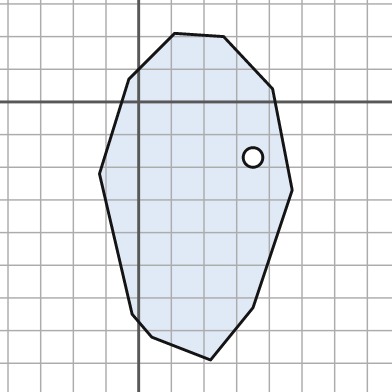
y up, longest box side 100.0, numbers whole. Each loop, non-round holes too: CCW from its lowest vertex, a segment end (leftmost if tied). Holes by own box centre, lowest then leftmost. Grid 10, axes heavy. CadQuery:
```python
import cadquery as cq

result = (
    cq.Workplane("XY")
    .moveTo(22.0, -79.0)
    .lineTo(35.0, -63.0)
    .lineTo(47.0, -27.0)
    .lineTo(41.0, 4.0)
    .lineTo(26.0, 20.0)
    .lineTo(11.0, 21.0)
    .lineTo(-3.0, 7.0)
    .lineTo(-12.0, -22.0)
    .lineTo(-2.0, -65.0)
    .lineTo(4.0, -72.0)
    .close()
    .moveTo(35.0, -17.0)
    .circle(3.0)
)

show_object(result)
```